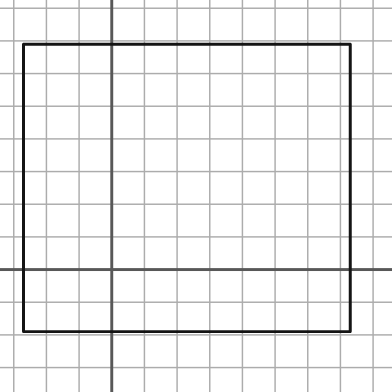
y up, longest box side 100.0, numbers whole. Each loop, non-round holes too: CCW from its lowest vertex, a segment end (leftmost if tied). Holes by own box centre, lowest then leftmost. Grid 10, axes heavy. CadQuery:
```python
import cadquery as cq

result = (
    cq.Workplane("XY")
    .moveTo(-27.0, -19.0)
    .lineTo(73.0, -19.0)
    .lineTo(73.0, 69.0)
    .lineTo(-27.0, 69.0)
    .close()
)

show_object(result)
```